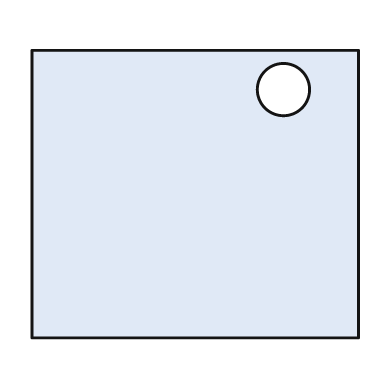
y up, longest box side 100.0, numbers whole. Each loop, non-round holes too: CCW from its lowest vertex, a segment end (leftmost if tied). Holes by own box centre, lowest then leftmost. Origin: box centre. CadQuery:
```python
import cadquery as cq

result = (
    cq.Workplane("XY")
    .moveTo(-50.0, -44.0)
    .lineTo(50.0, -44.0)
    .lineTo(50.0, 44.0)
    .lineTo(-50.0, 44.0)
    .close()
    .moveTo(27.0, 32.0)
    .circle(8.0)
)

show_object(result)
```